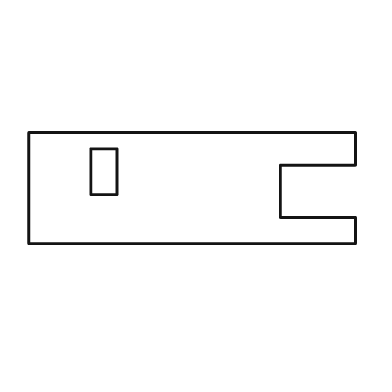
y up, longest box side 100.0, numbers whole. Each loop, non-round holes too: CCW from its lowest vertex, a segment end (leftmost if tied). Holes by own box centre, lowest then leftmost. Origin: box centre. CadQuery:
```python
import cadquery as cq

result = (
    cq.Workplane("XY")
    .moveTo(-50.0, -17.0)
    .lineTo(50.0, -17.0)
    .lineTo(50.0, -9.0)
    .lineTo(27.0, -9.0)
    .lineTo(27.0, 7.0)
    .lineTo(50.0, 7.0)
    .lineTo(50.0, 17.0)
    .lineTo(-50.0, 17.0)
    .close()
    .moveTo(-31.0, -2.0)
    .lineTo(-23.0, -2.0)
    .lineTo(-23.0, 12.0)
    .lineTo(-31.0, 12.0)
    .close()
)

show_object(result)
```